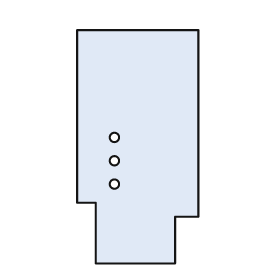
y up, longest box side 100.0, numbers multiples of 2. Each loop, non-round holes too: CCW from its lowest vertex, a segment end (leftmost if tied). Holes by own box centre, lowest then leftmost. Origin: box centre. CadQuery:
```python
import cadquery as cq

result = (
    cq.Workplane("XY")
    .moveTo(-18.0, -50.0)
    .lineTo(16.0, -50.0)
    .lineTo(16.0, -30.0)
    .lineTo(26.0, -30.0)
    .lineTo(26.0, 50.0)
    .lineTo(-26.0, 50.0)
    .lineTo(-26.0, -24.0)
    .lineTo(-18.0, -24.0)
    .close()
    .moveTo(-10.0, -16.0)
    .circle(2.0)
    .moveTo(-10.0, -6.0)
    .circle(2.0)
    .moveTo(-10.0, 4.0)
    .circle(2.0)
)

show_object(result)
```